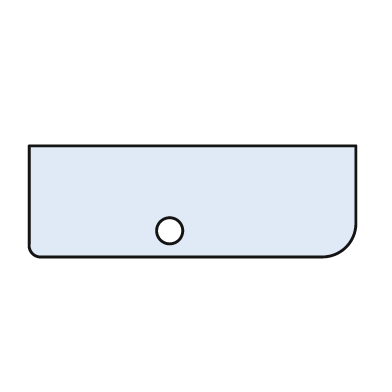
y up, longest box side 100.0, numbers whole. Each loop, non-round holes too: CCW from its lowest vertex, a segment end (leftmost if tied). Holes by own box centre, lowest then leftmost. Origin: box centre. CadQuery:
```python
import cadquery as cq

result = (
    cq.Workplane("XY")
    .moveTo(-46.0, -17.0)
    .lineTo(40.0, -17.0)
    .threePointArc((47.0, -14.0), (50.0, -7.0))
    .lineTo(50.0, 17.0)
    .lineTo(-50.0, 17.0)
    .lineTo(-50.0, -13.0)
    .threePointArc((-49.0, -16.0), (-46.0, -17.0))
    .close()
    .moveTo(-7.0, -9.0)
    .circle(4.0)
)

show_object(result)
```